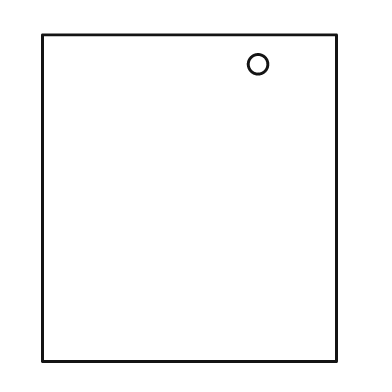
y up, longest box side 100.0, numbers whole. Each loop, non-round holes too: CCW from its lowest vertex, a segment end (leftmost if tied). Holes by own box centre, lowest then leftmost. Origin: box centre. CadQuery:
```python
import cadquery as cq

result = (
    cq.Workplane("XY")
    .moveTo(-45.0, -50.0)
    .lineTo(45.0, -50.0)
    .lineTo(45.0, 50.0)
    .lineTo(-45.0, 50.0)
    .close()
    .moveTo(21.0, 41.0)
    .circle(3.0)
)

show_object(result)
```